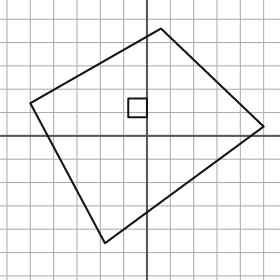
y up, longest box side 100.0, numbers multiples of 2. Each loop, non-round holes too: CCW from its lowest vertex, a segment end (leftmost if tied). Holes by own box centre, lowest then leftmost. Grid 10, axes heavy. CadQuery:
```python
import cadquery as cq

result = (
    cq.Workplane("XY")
    .moveTo(-18.0, -46.0)
    .lineTo(50.0, 4.0)
    .lineTo(6.0, 46.0)
    .lineTo(-50.0, 14.0)
    .close()
    .moveTo(-8.0, 8.0)
    .lineTo(0.0, 8.0)
    .lineTo(0.0, 16.0)
    .lineTo(-8.0, 16.0)
    .close()
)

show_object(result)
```